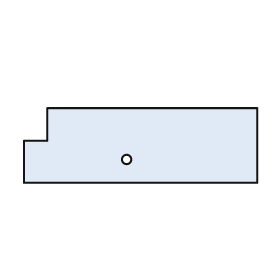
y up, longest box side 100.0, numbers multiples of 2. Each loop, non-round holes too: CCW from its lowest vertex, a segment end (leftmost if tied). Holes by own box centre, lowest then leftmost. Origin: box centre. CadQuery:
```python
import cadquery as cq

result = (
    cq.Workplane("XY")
    .moveTo(-50.0, -16.0)
    .lineTo(50.0, -16.0)
    .lineTo(50.0, 16.0)
    .lineTo(-40.0, 16.0)
    .lineTo(-40.0, 2.0)
    .lineTo(-50.0, 2.0)
    .close()
    .moveTo(-6.0, -6.0)
    .circle(2.0)
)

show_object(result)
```